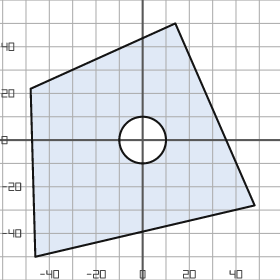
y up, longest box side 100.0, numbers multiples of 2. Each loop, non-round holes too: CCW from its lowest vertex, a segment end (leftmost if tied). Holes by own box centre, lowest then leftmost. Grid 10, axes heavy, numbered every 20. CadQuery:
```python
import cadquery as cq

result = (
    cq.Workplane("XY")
    .moveTo(-46.0, -50.0)
    .lineTo(48.0, -28.0)
    .lineTo(14.0, 50.0)
    .lineTo(-48.0, 22.0)
    .close()
    .moveTo(0.0, 0.0)
    .circle(10.0)
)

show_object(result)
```